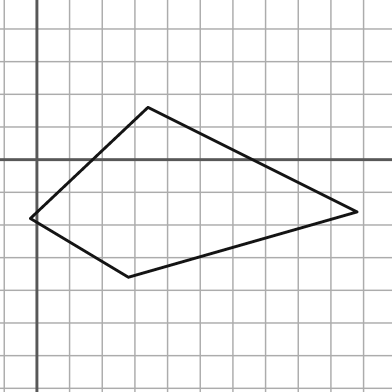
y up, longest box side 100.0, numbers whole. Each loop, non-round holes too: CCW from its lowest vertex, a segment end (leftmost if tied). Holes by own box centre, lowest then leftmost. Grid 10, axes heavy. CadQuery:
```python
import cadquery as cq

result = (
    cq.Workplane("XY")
    .moveTo(28.0, -36.0)
    .lineTo(98.0, -16.0)
    .lineTo(34.0, 16.0)
    .lineTo(-2.0, -18.0)
    .close()
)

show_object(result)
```